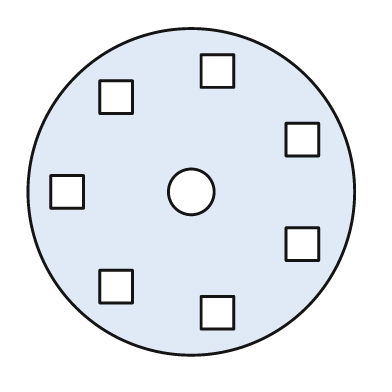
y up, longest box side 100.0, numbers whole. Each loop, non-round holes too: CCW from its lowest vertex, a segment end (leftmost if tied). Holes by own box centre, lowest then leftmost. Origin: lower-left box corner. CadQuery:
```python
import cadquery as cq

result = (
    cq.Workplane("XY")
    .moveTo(50.0, 50.0)
    .circle(50.0)
    .moveTo(53.0, 8.0)
    .lineTo(63.0, 8.0)
    .lineTo(63.0, 18.0)
    .lineTo(53.0, 18.0)
    .close()
    .moveTo(22.0, 16.0)
    .lineTo(32.0, 16.0)
    .lineTo(32.0, 26.0)
    .lineTo(22.0, 26.0)
    .close()
    .moveTo(79.0, 29.0)
    .lineTo(89.0, 29.0)
    .lineTo(89.0, 39.0)
    .lineTo(79.0, 39.0)
    .close()
    .moveTo(7.0, 45.0)
    .lineTo(17.0, 45.0)
    .lineTo(17.0, 55.0)
    .lineTo(7.0, 55.0)
    .close()
    .moveTo(50.0, 50.0)
    .circle(7.0)
    .moveTo(79.0, 61.0)
    .lineTo(89.0, 61.0)
    .lineTo(89.0, 71.0)
    .lineTo(79.0, 71.0)
    .close()
    .moveTo(22.0, 74.0)
    .lineTo(32.0, 74.0)
    .lineTo(32.0, 84.0)
    .lineTo(22.0, 84.0)
    .close()
    .moveTo(53.0, 82.0)
    .lineTo(63.0, 82.0)
    .lineTo(63.0, 92.0)
    .lineTo(53.0, 92.0)
    .close()
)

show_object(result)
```